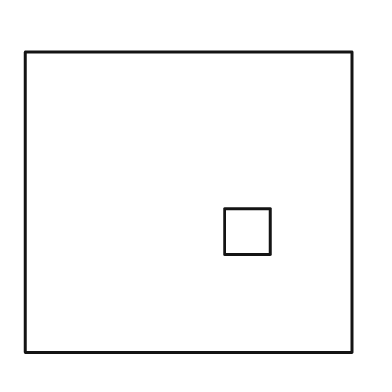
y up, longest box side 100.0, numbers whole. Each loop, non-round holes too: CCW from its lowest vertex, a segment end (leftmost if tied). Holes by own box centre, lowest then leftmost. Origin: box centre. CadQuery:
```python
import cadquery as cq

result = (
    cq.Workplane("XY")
    .moveTo(-50.0, -46.0)
    .lineTo(50.0, -46.0)
    .lineTo(50.0, 46.0)
    .lineTo(-50.0, 46.0)
    .close()
    .moveTo(11.0, -16.0)
    .lineTo(25.0, -16.0)
    .lineTo(25.0, -2.0)
    .lineTo(11.0, -2.0)
    .close()
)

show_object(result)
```